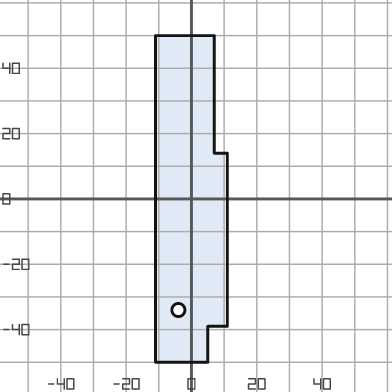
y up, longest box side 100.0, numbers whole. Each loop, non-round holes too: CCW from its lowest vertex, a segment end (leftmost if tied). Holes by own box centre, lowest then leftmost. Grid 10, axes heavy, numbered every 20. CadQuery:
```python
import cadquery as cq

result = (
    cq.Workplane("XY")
    .moveTo(-11.0, -50.0)
    .lineTo(5.0, -50.0)
    .lineTo(5.0, -39.0)
    .lineTo(11.0, -39.0)
    .lineTo(11.0, 14.0)
    .lineTo(7.0, 14.0)
    .lineTo(7.0, 50.0)
    .lineTo(-11.0, 50.0)
    .close()
    .moveTo(-4.0, -34.0)
    .circle(2.0)
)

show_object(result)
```